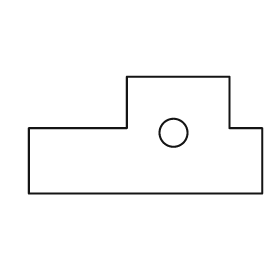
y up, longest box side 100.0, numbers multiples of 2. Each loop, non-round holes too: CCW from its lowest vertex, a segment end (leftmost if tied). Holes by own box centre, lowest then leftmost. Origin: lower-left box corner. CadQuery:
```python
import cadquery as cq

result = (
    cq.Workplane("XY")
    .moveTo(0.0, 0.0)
    .lineTo(100.0, 0.0)
    .lineTo(100.0, 28.0)
    .lineTo(86.0, 28.0)
    .lineTo(86.0, 50.0)
    .lineTo(42.0, 50.0)
    .lineTo(42.0, 28.0)
    .lineTo(0.0, 28.0)
    .close()
    .moveTo(62.0, 26.0)
    .circle(6.0)
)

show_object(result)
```